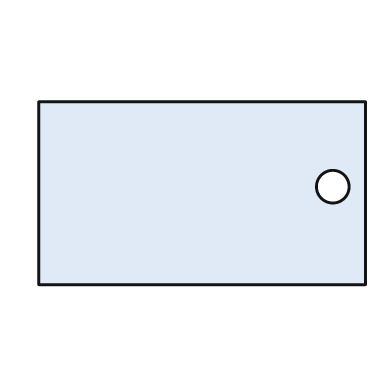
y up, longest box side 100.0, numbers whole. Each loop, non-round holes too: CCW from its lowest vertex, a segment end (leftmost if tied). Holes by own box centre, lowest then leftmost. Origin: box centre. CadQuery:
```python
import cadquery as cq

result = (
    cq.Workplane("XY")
    .moveTo(-50.0, -28.0)
    .lineTo(50.0, -28.0)
    .lineTo(50.0, 28.0)
    .lineTo(-50.0, 28.0)
    .close()
    .moveTo(40.0, 2.0)
    .circle(5.0)
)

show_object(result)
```